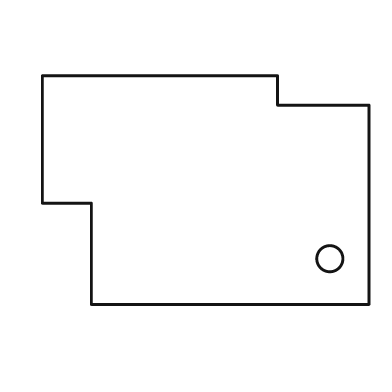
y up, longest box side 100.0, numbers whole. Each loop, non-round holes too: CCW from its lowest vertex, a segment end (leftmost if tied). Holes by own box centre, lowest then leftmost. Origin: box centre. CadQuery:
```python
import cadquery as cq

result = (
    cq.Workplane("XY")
    .moveTo(-35.0, -35.0)
    .lineTo(50.0, -35.0)
    .lineTo(50.0, 26.0)
    .lineTo(22.0, 26.0)
    .lineTo(22.0, 35.0)
    .lineTo(-50.0, 35.0)
    .lineTo(-50.0, -4.0)
    .lineTo(-35.0, -4.0)
    .close()
    .moveTo(38.0, -21.0)
    .circle(4.0)
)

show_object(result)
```